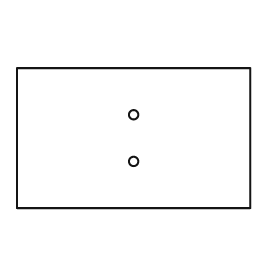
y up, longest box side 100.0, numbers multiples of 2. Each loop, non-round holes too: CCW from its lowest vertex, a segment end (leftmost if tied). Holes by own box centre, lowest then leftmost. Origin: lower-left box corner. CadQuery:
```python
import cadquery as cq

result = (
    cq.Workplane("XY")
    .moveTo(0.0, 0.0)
    .lineTo(100.0, 0.0)
    .lineTo(100.0, 60.0)
    .lineTo(0.0, 60.0)
    .close()
    .moveTo(50.0, 20.0)
    .circle(2.0)
    .moveTo(50.0, 40.0)
    .circle(2.0)
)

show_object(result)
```